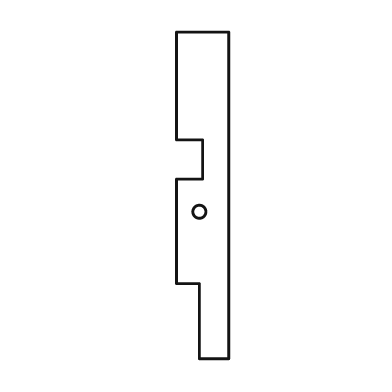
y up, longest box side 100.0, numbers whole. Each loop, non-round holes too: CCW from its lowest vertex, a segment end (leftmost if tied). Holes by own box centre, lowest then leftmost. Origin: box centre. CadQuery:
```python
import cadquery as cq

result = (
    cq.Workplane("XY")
    .moveTo(-1.0, -50.0)
    .lineTo(8.0, -50.0)
    .lineTo(8.0, 50.0)
    .lineTo(-8.0, 50.0)
    .lineTo(-8.0, 17.0)
    .lineTo(0.0, 17.0)
    .lineTo(0.0, 5.0)
    .lineTo(-8.0, 5.0)
    .lineTo(-8.0, -27.0)
    .lineTo(-1.0, -27.0)
    .close()
    .moveTo(-1.0, -5.0)
    .circle(2.0)
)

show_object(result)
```